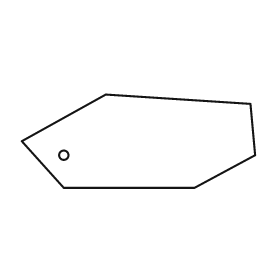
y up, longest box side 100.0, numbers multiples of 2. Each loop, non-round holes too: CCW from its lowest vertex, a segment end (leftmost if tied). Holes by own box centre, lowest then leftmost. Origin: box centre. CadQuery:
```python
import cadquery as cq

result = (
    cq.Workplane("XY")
    .moveTo(-32.0, -20.0)
    .lineTo(24.0, -20.0)
    .lineTo(50.0, -6.0)
    .lineTo(48.0, 16.0)
    .lineTo(-14.0, 20.0)
    .lineTo(-50.0, 0.0)
    .close()
    .moveTo(-32.0, -6.0)
    .circle(2.0)
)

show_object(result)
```